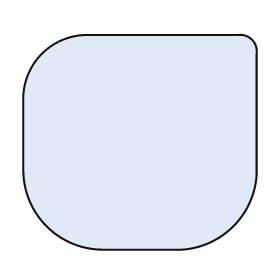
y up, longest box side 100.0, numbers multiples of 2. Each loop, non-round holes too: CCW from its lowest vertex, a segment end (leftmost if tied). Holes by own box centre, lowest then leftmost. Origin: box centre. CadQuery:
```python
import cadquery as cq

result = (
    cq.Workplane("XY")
    .moveTo(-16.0, -46.0)
    .lineTo(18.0, -46.0)
    .threePointArc((40.0, -36.0), (50.0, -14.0))
    .lineTo(50.0, 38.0)
    .threePointArc((48.0, 44.0), (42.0, 46.0))
    .lineTo(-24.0, 46.0)
    .threePointArc((-42.0, 38.0), (-50.0, 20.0))
    .lineTo(-50.0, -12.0)
    .threePointArc((-40.0, -36.0), (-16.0, -46.0))
    .close()
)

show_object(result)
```